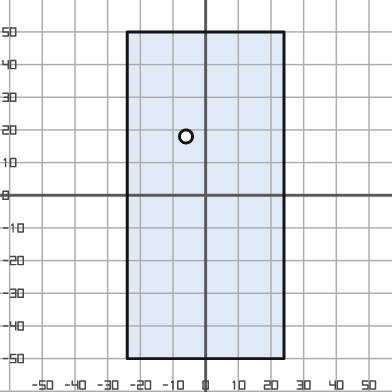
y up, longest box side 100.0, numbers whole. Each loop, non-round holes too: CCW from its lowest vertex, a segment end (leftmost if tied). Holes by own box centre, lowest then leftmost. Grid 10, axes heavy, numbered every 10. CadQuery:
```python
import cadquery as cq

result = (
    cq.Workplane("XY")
    .moveTo(-24.0, -50.0)
    .lineTo(24.0, -50.0)
    .lineTo(24.0, 50.0)
    .lineTo(-24.0, 50.0)
    .close()
    .moveTo(-6.0, 18.0)
    .circle(2.0)
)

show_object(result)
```